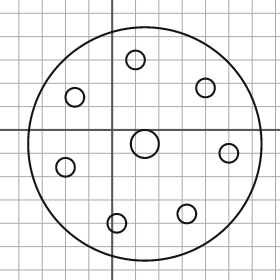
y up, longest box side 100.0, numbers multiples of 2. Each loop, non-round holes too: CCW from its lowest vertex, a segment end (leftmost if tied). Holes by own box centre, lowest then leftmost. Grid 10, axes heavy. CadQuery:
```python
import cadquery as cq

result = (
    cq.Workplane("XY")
    .moveTo(14.0, -6.0)
    .circle(50.0)
    .moveTo(2.0, -40.0)
    .circle(4.0)
    .moveTo(32.0, -36.0)
    .circle(4.0)
    .moveTo(-20.0, -16.0)
    .circle(4.0)
    .moveTo(50.0, -10.0)
    .circle(4.0)
    .moveTo(14.0, -6.0)
    .circle(6.0)
    .moveTo(-16.0, 14.0)
    .circle(4.0)
    .moveTo(40.0, 18.0)
    .circle(4.0)
    .moveTo(10.0, 30.0)
    .circle(4.0)
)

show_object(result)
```